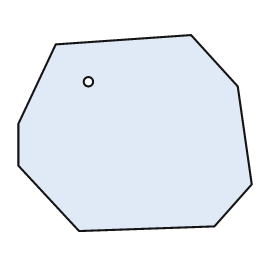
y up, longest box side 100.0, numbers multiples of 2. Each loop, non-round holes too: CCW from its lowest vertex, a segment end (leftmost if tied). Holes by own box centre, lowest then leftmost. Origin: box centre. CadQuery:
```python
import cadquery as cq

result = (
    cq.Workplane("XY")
    .moveTo(-24.0, -42.0)
    .lineTo(34.0, -40.0)
    .lineTo(50.0, -22.0)
    .lineTo(44.0, 20.0)
    .lineTo(24.0, 42.0)
    .lineTo(-34.0, 38.0)
    .lineTo(-50.0, 4.0)
    .lineTo(-50.0, -14.0)
    .close()
    .moveTo(-20.0, 22.0)
    .circle(2.0)
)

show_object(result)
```